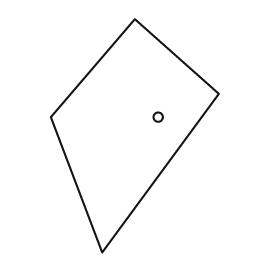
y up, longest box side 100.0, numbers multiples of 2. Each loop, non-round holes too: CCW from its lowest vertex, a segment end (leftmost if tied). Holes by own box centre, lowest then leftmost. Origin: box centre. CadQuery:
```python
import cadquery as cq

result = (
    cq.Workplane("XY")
    .moveTo(-14.0, -50.0)
    .lineTo(36.0, 18.0)
    .lineTo(0.0, 50.0)
    .lineTo(-36.0, 8.0)
    .close()
    .moveTo(10.0, 8.0)
    .circle(2.0)
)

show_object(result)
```